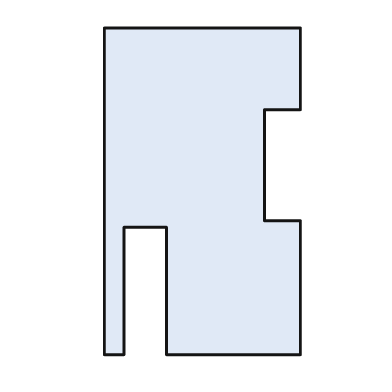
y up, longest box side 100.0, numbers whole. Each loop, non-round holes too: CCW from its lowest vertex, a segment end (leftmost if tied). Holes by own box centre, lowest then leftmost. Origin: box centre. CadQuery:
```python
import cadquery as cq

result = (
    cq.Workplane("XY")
    .moveTo(-30.0, -50.0)
    .lineTo(-24.0, -50.0)
    .lineTo(-24.0, -11.0)
    .lineTo(-11.0, -11.0)
    .lineTo(-11.0, -50.0)
    .lineTo(30.0, -50.0)
    .lineTo(30.0, -9.0)
    .lineTo(19.0, -9.0)
    .lineTo(19.0, 25.0)
    .lineTo(30.0, 25.0)
    .lineTo(30.0, 50.0)
    .lineTo(-30.0, 50.0)
    .close()
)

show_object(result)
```